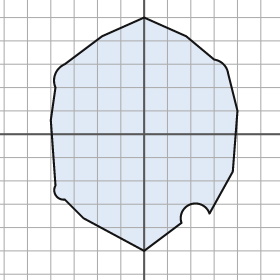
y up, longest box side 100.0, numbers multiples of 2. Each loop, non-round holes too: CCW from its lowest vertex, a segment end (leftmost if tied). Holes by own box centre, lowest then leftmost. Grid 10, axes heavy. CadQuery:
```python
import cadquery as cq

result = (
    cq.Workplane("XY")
    .moveTo(0.0, -50.0)
    .lineTo(16.0, -38.0)
    .threePointArc((20.0, -30.0), (28.0, -34.0))
    .lineTo(38.0, -16.0)
    .lineTo(40.0, 10.0)
    .lineTo(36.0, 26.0)
    .threePointArc((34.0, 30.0), (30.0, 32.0))
    .lineTo(18.0, 42.0)
    .lineTo(0.0, 50.0)
    .lineTo(-18.0, 42.0)
    .lineTo(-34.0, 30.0)
    .threePointArc((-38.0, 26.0), (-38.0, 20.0))
    .lineTo(-40.0, 6.0)
    .lineTo(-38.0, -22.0)
    .threePointArc((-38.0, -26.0), (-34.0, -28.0))
    .lineTo(-26.0, -36.0)
    .close()
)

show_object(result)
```